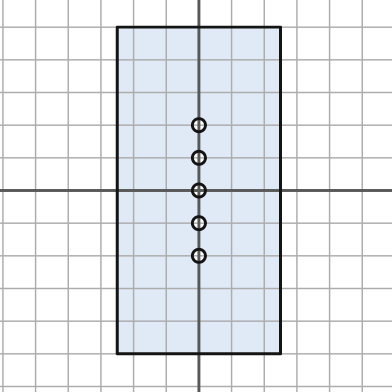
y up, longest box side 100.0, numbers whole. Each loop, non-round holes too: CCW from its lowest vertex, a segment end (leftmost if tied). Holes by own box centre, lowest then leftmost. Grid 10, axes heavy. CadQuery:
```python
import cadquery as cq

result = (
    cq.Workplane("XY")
    .moveTo(-25.0, -50.0)
    .lineTo(25.0, -50.0)
    .lineTo(25.0, 50.0)
    .lineTo(-25.0, 50.0)
    .close()
    .moveTo(0.0, -20.0)
    .circle(2.0)
    .moveTo(0.0, -10.0)
    .circle(2.0)
    .moveTo(0.0, 0.0)
    .circle(2.0)
    .moveTo(0.0, 10.0)
    .circle(2.0)
    .moveTo(0.0, 20.0)
    .circle(2.0)
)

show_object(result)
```